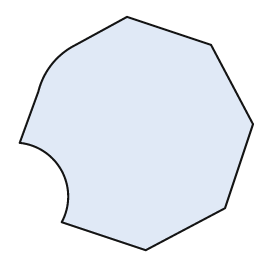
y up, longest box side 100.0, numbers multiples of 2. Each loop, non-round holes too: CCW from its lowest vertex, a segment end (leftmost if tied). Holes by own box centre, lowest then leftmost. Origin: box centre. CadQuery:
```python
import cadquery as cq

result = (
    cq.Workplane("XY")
    .moveTo(4.0, -50.0)
    .lineTo(38.0, -32.0)
    .lineTo(50.0, 4.0)
    .lineTo(32.0, 38.0)
    .lineTo(-4.0, 50.0)
    .lineTo(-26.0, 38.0)
    .threePointArc((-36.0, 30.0), (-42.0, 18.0))
    .lineTo(-50.0, -4.0)
    .threePointArc((-32.0, -16.0), (-32.0, -38.0))
    .close()
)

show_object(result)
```